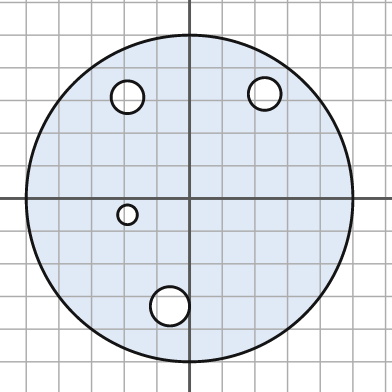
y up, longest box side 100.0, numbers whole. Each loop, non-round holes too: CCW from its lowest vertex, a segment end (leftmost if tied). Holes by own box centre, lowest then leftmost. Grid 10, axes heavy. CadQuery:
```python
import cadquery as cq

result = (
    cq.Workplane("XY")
    .moveTo(0.0, 0.0)
    .circle(50.0)
    .moveTo(-6.0, -33.0)
    .circle(6.0)
    .moveTo(-19.0, -5.0)
    .circle(3.0)
    .moveTo(-19.0, 31.0)
    .circle(5.0)
    .moveTo(23.0, 32.0)
    .circle(5.0)
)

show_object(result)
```